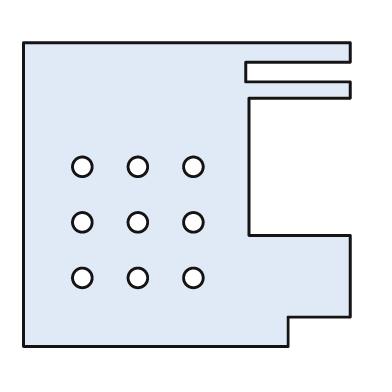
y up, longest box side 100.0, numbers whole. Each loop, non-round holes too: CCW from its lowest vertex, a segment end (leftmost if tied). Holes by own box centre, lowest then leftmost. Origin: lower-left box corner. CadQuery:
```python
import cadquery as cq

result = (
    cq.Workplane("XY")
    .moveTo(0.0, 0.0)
    .lineTo(81.0, 0.0)
    .lineTo(81.0, 9.0)
    .lineTo(100.0, 9.0)
    .lineTo(100.0, 34.0)
    .lineTo(69.0, 34.0)
    .lineTo(69.0, 76.0)
    .lineTo(100.0, 76.0)
    .lineTo(100.0, 81.0)
    .lineTo(68.0, 81.0)
    .lineTo(68.0, 87.0)
    .lineTo(100.0, 87.0)
    .lineTo(100.0, 93.0)
    .lineTo(0.0, 93.0)
    .close()
    .moveTo(18.0, 21.0)
    .circle(3.0)
    .moveTo(35.0, 21.0)
    .circle(3.0)
    .moveTo(52.0, 21.0)
    .circle(3.0)
    .moveTo(18.0, 38.0)
    .circle(3.0)
    .moveTo(35.0, 38.0)
    .circle(3.0)
    .moveTo(52.0, 38.0)
    .circle(3.0)
    .moveTo(18.0, 55.0)
    .circle(3.0)
    .moveTo(35.0, 55.0)
    .circle(3.0)
    .moveTo(52.0, 55.0)
    .circle(3.0)
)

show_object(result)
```